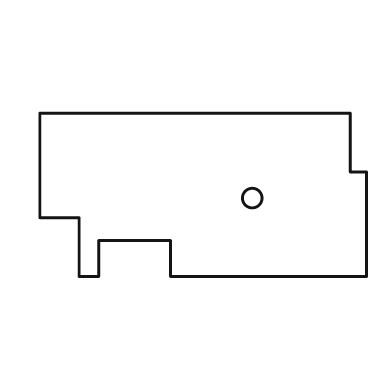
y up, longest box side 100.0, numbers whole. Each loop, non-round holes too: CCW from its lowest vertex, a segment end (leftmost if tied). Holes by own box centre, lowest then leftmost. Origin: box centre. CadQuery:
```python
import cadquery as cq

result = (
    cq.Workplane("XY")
    .moveTo(-38.0, -25.0)
    .lineTo(-32.0, -25.0)
    .lineTo(-32.0, -14.0)
    .lineTo(-10.0, -14.0)
    .lineTo(-10.0, -25.0)
    .lineTo(50.0, -25.0)
    .lineTo(50.0, 7.0)
    .lineTo(45.0, 7.0)
    .lineTo(45.0, 25.0)
    .lineTo(-50.0, 25.0)
    .lineTo(-50.0, -7.0)
    .lineTo(-38.0, -7.0)
    .close()
    .moveTo(15.0, -1.0)
    .circle(3.0)
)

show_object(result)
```